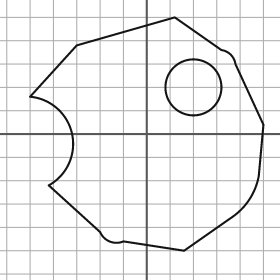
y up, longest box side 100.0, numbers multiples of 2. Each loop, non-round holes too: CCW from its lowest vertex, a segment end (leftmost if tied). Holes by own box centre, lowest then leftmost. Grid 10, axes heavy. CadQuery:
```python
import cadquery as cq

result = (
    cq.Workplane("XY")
    .moveTo(16.0, -50.0)
    .lineTo(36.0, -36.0)
    .threePointArc((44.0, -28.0), (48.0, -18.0))
    .lineTo(50.0, 4.0)
    .lineTo(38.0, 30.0)
    .threePointArc((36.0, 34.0), (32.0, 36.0))
    .lineTo(12.0, 50.0)
    .lineTo(-30.0, 38.0)
    .lineTo(-50.0, 16.0)
    .threePointArc((-32.0, 0.0), (-42.0, -22.0))
    .lineTo(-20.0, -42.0)
    .threePointArc((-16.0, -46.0), (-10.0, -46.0))
    .close()
    .moveTo(20.0, 20.0)
    .circle(12.0)
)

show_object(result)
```